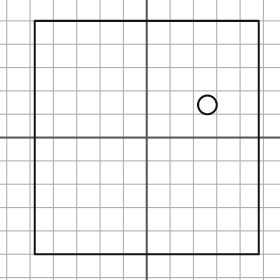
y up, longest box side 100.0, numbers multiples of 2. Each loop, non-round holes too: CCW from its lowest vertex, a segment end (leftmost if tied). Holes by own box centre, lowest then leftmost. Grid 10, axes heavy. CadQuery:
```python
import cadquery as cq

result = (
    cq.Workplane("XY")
    .moveTo(-48.0, -50.0)
    .lineTo(48.0, -50.0)
    .lineTo(48.0, 50.0)
    .lineTo(-48.0, 50.0)
    .close()
    .moveTo(26.0, 14.0)
    .circle(4.0)
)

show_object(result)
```